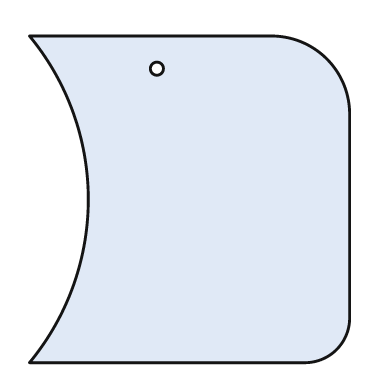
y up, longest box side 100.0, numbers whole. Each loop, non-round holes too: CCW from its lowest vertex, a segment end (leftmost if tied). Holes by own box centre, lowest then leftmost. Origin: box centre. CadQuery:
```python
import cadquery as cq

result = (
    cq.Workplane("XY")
    .moveTo(-49.0, -50.0)
    .lineTo(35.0, -50.0)
    .threePointArc((45.0, -46.0), (49.0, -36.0))
    .lineTo(49.0, 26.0)
    .threePointArc((42.0, 43.0), (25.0, 50.0))
    .lineTo(-49.0, 50.0)
    .threePointArc((-31.0, 0.0), (-49.0, -50.0))
    .close()
    .moveTo(-10.0, 40.0)
    .circle(2.0)
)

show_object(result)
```